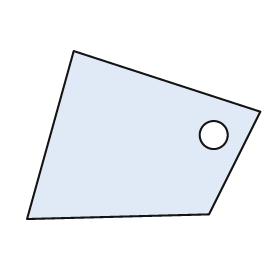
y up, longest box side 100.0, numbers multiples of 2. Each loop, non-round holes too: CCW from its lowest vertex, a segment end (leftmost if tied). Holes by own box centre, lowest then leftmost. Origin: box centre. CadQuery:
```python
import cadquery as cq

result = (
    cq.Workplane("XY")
    .moveTo(-50.0, -36.0)
    .lineTo(28.0, -34.0)
    .lineTo(50.0, 10.0)
    .lineTo(-30.0, 36.0)
    .close()
    .moveTo(30.0, 0.0)
    .circle(6.0)
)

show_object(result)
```